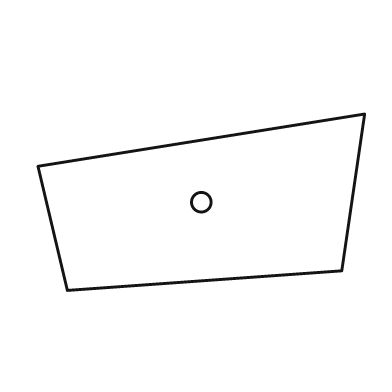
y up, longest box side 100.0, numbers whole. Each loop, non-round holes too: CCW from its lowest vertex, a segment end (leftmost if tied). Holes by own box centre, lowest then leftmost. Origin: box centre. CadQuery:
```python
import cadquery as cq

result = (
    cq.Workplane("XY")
    .moveTo(-41.0, -27.0)
    .lineTo(43.0, -21.0)
    .lineTo(50.0, 27.0)
    .lineTo(-50.0, 11.0)
    .close()
    .moveTo(0.0, 0.0)
    .circle(3.0)
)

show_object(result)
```